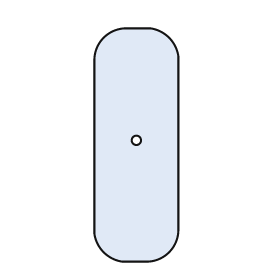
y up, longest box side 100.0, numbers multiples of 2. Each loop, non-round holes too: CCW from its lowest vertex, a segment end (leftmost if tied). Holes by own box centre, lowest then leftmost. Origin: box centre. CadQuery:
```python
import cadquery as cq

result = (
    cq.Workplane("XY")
    .moveTo(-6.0, -50.0)
    .lineTo(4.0, -50.0)
    .threePointArc((14.0, -46.0), (18.0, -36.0))
    .lineTo(18.0, 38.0)
    .threePointArc((14.0, 46.0), (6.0, 50.0))
    .lineTo(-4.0, 50.0)
    .threePointArc((-14.0, 46.0), (-18.0, 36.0))
    .lineTo(-18.0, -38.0)
    .threePointArc((-14.0, -46.0), (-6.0, -50.0))
    .close()
    .moveTo(0.0, 2.0)
    .circle(2.0)
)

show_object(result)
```